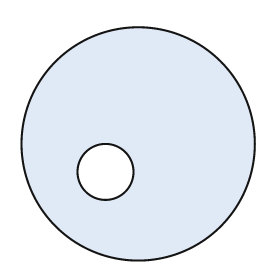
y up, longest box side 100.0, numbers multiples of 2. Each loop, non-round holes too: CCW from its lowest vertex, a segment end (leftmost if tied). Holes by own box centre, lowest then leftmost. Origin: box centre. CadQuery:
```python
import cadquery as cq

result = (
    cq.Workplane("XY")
    .moveTo(0.0, 0.0)
    .circle(50.0)
    .moveTo(-14.0, -12.0)
    .circle(12.0)
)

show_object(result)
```